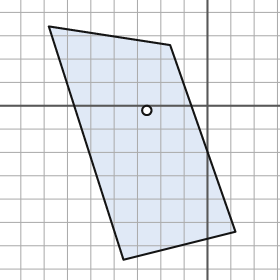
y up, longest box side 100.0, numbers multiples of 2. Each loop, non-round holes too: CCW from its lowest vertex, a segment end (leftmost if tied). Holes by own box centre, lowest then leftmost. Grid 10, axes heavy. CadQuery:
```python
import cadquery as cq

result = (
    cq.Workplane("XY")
    .moveTo(-36.0, -66.0)
    .lineTo(12.0, -54.0)
    .lineTo(-16.0, 26.0)
    .lineTo(-68.0, 34.0)
    .close()
    .moveTo(-26.0, -2.0)
    .circle(2.0)
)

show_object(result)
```